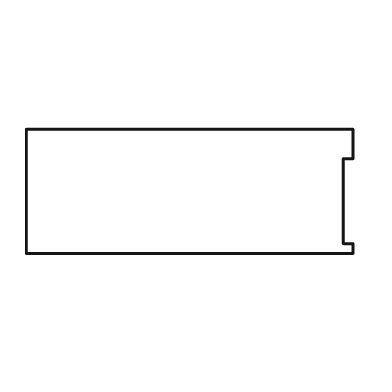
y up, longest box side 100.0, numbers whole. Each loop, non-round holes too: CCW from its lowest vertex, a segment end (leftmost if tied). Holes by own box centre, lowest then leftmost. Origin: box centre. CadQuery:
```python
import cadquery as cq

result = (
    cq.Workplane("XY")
    .moveTo(-50.0, -19.0)
    .lineTo(50.0, -19.0)
    .lineTo(50.0, -16.0)
    .lineTo(47.0, -16.0)
    .lineTo(47.0, 10.0)
    .lineTo(50.0, 10.0)
    .lineTo(50.0, 19.0)
    .lineTo(-50.0, 19.0)
    .close()
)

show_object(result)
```